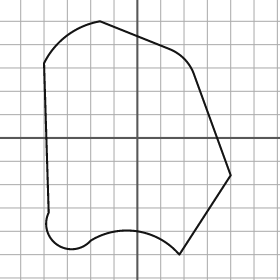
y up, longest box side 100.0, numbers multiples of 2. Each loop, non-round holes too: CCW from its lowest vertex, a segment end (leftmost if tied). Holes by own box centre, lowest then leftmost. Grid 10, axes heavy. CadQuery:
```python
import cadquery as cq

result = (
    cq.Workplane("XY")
    .moveTo(18.0, -50.0)
    .lineTo(40.0, -16.0)
    .lineTo(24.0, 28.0)
    .threePointArc((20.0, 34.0), (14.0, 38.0))
    .lineTo(-16.0, 50.0)
    .threePointArc((-30.0, 44.0), (-40.0, 32.0))
    .lineTo(-38.0, -32.0)
    .threePointArc((-34.0, -46.0), (-20.0, -44.0))
    .threePointArc((0.0, -40.0), (18.0, -50.0))
    .close()
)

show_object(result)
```